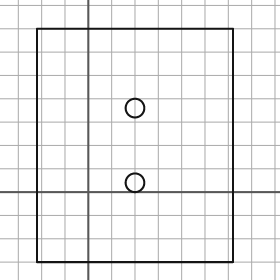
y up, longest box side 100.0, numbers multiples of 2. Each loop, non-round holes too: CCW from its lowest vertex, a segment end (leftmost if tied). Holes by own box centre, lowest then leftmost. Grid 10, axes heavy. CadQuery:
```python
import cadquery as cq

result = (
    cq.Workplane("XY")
    .moveTo(-22.0, -30.0)
    .lineTo(62.0, -30.0)
    .lineTo(62.0, 70.0)
    .lineTo(-22.0, 70.0)
    .close()
    .moveTo(20.0, 4.0)
    .circle(4.0)
    .moveTo(20.0, 36.0)
    .circle(4.0)
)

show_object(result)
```